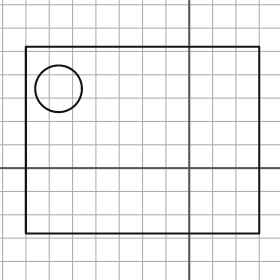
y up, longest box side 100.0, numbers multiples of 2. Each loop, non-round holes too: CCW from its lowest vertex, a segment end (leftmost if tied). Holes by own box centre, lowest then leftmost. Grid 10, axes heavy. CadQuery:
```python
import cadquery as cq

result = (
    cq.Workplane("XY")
    .moveTo(-70.0, -28.0)
    .lineTo(30.0, -28.0)
    .lineTo(30.0, 52.0)
    .lineTo(-70.0, 52.0)
    .close()
    .moveTo(-56.0, 34.0)
    .circle(10.0)
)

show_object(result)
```